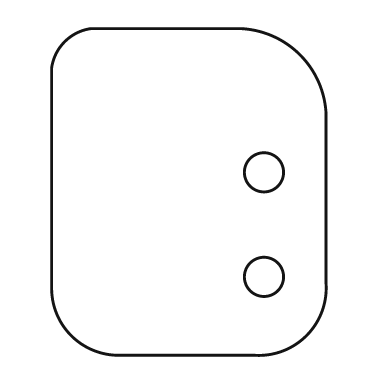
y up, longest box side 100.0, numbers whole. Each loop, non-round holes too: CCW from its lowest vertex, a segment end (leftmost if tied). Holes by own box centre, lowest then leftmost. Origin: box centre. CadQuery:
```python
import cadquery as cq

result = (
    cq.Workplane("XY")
    .moveTo(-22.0, -50.0)
    .lineTo(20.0, -50.0)
    .threePointArc((36.0, -44.0), (42.0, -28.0))
    .lineTo(42.0, 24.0)
    .threePointArc((34.0, 42.0), (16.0, 50.0))
    .lineTo(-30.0, 50.0)
    .threePointArc((-38.0, 46.0), (-42.0, 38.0))
    .lineTo(-42.0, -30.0)
    .threePointArc((-36.0, -44.0), (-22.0, -50.0))
    .close()
    .moveTo(23.0, -26.0)
    .circle(6.0)
    .moveTo(23.0, 6.0)
    .circle(6.0)
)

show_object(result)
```